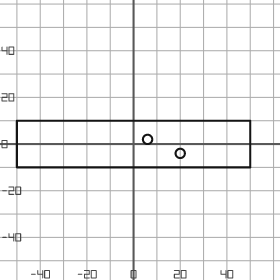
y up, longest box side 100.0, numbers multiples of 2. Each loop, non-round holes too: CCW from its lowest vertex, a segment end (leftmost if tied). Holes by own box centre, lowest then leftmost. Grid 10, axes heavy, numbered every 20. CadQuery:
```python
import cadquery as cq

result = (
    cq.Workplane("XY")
    .moveTo(-50.0, -10.0)
    .lineTo(50.0, -10.0)
    .lineTo(50.0, 10.0)
    .lineTo(-50.0, 10.0)
    .close()
    .moveTo(20.0, -4.0)
    .circle(2.0)
    .moveTo(6.0, 2.0)
    .circle(2.0)
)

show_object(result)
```